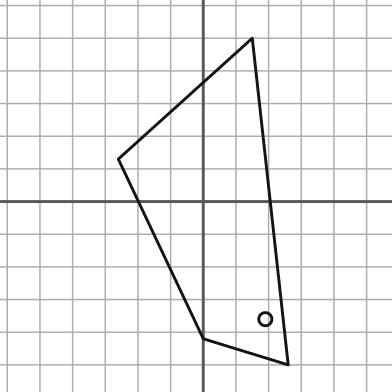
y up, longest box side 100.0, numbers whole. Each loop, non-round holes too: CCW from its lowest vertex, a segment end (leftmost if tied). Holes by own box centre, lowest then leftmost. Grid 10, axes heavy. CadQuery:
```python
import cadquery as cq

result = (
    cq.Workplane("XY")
    .moveTo(26.0, -50.0)
    .lineTo(15.0, 50.0)
    .lineTo(-26.0, 13.0)
    .lineTo(0.0, -42.0)
    .close()
    .moveTo(19.0, -36.0)
    .circle(2.0)
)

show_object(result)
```